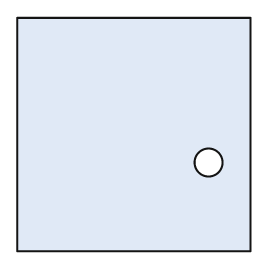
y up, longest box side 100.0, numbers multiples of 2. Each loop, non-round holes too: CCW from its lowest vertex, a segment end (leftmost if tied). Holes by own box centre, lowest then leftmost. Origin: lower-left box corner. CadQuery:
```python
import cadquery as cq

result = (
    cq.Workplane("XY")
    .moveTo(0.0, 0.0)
    .lineTo(100.0, 0.0)
    .lineTo(100.0, 100.0)
    .lineTo(0.0, 100.0)
    .close()
    .moveTo(82.0, 38.0)
    .circle(6.0)
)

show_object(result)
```